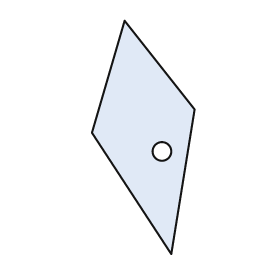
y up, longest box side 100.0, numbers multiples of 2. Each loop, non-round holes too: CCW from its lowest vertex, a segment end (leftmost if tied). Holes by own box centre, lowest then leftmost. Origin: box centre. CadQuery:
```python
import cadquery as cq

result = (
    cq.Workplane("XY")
    .moveTo(12.0, -50.0)
    .lineTo(22.0, 12.0)
    .lineTo(-8.0, 50.0)
    .lineTo(-22.0, 2.0)
    .close()
    .moveTo(8.0, -6.0)
    .circle(4.0)
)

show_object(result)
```